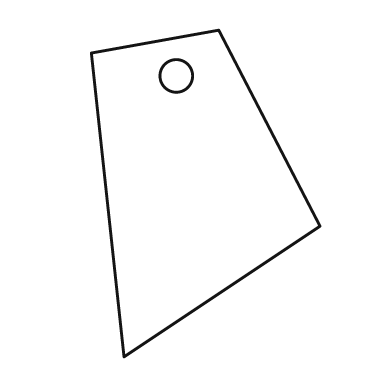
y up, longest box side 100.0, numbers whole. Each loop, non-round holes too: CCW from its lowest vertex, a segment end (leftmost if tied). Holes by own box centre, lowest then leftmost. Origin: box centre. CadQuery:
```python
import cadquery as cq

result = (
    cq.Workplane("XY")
    .moveTo(-25.0, -50.0)
    .lineTo(35.0, -10.0)
    .lineTo(4.0, 50.0)
    .lineTo(-35.0, 43.0)
    .close()
    .moveTo(-9.0, 36.0)
    .circle(5.0)
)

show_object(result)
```